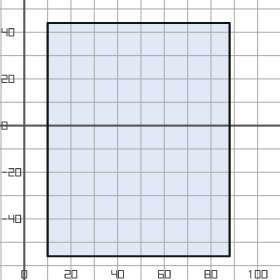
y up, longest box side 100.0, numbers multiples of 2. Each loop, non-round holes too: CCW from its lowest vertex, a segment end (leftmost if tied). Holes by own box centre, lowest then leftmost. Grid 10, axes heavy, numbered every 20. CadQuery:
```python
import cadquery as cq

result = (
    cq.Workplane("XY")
    .moveTo(10.0, -56.0)
    .lineTo(88.0, -56.0)
    .lineTo(88.0, 44.0)
    .lineTo(10.0, 44.0)
    .close()
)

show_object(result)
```